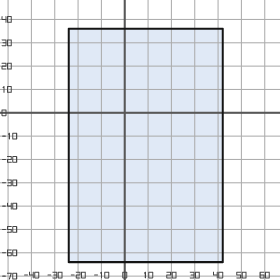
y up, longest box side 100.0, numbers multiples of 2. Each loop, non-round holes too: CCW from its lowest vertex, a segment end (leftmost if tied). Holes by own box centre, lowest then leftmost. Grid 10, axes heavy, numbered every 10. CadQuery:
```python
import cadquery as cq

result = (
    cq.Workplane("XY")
    .moveTo(-24.0, -64.0)
    .lineTo(42.0, -64.0)
    .lineTo(42.0, 36.0)
    .lineTo(-24.0, 36.0)
    .close()
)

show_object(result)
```